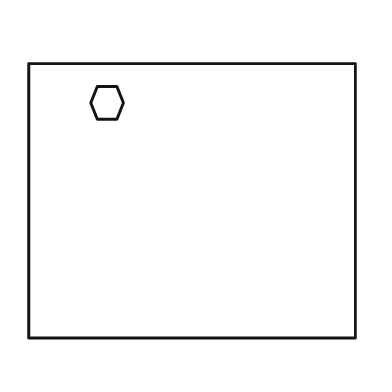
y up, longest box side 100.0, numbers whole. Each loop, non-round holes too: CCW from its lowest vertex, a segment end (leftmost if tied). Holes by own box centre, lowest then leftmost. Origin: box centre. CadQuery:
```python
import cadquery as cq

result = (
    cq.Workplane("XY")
    .moveTo(-50.0, -42.0)
    .lineTo(50.0, -42.0)
    .lineTo(50.0, 42.0)
    .lineTo(-50.0, 42.0)
    .close()
    .moveTo(-29.0, 25.0)
    .lineTo(-23.0, 25.0)
    .lineTo(-21.0, 30.0)
    .lineTo(-23.0, 35.0)
    .lineTo(-29.0, 35.0)
    .lineTo(-31.0, 30.0)
    .close()
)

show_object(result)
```